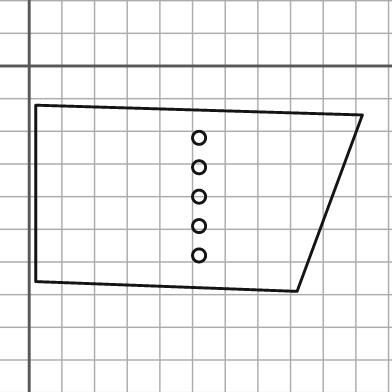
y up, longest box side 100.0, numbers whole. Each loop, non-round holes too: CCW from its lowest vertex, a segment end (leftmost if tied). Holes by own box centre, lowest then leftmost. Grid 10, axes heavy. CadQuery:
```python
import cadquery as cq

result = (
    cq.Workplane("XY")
    .moveTo(82.0, -69.0)
    .lineTo(102.0, -15.0)
    .lineTo(2.0, -12.0)
    .lineTo(2.0, -66.0)
    .close()
    .moveTo(52.0, -58.0)
    .circle(2.0)
    .moveTo(52.0, -49.0)
    .circle(2.0)
    .moveTo(52.0, -40.0)
    .circle(2.0)
    .moveTo(52.0, -31.0)
    .circle(2.0)
    .moveTo(52.0, -22.0)
    .circle(2.0)
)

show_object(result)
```